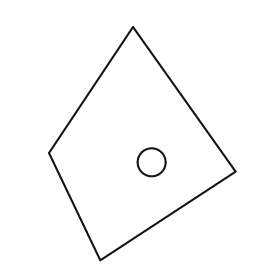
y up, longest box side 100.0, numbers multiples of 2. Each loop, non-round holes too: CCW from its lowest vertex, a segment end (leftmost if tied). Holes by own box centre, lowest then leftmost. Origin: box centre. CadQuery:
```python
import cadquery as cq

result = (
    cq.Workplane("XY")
    .moveTo(-18.0, -50.0)
    .lineTo(40.0, -12.0)
    .lineTo(-4.0, 50.0)
    .lineTo(-40.0, -4.0)
    .close()
    .moveTo(4.0, -8.0)
    .circle(6.0)
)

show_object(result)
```